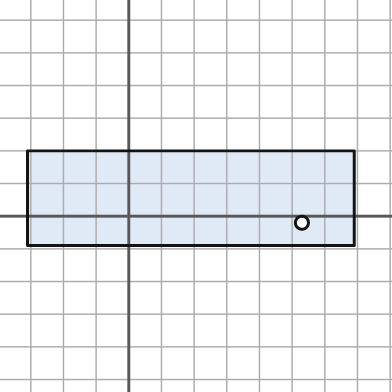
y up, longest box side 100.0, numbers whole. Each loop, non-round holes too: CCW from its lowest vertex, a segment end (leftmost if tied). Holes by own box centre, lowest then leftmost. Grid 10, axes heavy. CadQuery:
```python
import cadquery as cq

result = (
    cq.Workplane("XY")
    .moveTo(-31.0, -9.0)
    .lineTo(69.0, -9.0)
    .lineTo(69.0, 20.0)
    .lineTo(-31.0, 20.0)
    .close()
    .moveTo(53.0, -2.0)
    .circle(2.0)
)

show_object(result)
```